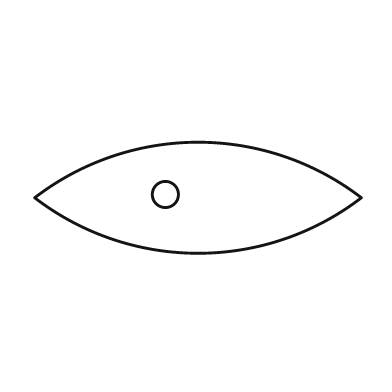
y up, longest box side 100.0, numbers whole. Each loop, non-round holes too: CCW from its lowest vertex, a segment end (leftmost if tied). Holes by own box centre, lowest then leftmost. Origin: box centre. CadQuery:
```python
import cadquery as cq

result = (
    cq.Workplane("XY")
    .moveTo(-50.0, 0.0)
    .threePointArc((0.0, -17.0), (50.0, 0.0))
    .threePointArc((0.0, 17.0), (-50.0, 0.0))
    .close()
    .moveTo(-10.0, 1.0)
    .circle(4.0)
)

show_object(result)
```